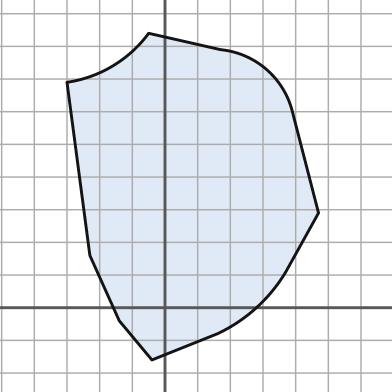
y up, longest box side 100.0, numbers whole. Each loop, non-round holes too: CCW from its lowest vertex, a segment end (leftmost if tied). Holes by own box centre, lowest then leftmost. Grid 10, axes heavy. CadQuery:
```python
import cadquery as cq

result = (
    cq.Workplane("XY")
    .moveTo(-4.0, -16.0)
    .lineTo(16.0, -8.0)
    .threePointArc((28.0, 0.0), (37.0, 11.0))
    .lineTo(47.0, 29.0)
    .lineTo(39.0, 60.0)
    .threePointArc((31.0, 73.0), (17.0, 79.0))
    .lineTo(-5.0, 84.0)
    .threePointArc((-16.0, 74.0), (-30.0, 69.0))
    .lineTo(-23.0, 16.0)
    .lineTo(-14.0, -4.0)
    .close()
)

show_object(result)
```